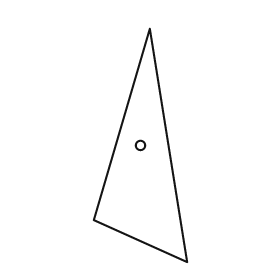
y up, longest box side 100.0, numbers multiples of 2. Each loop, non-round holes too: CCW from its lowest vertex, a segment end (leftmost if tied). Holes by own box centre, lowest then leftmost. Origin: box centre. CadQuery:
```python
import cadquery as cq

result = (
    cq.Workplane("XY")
    .moveTo(20.0, -50.0)
    .lineTo(4.0, 50.0)
    .lineTo(-20.0, -32.0)
    .close()
    .moveTo(0.0, 0.0)
    .circle(2.0)
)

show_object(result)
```